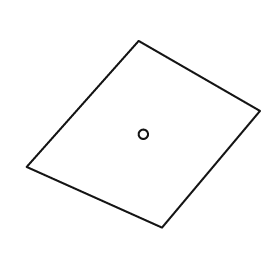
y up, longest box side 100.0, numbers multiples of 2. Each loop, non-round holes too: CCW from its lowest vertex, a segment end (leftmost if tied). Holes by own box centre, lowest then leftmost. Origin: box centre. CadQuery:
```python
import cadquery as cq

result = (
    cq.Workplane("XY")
    .moveTo(8.0, -40.0)
    .lineTo(50.0, 10.0)
    .lineTo(-2.0, 40.0)
    .lineTo(-50.0, -14.0)
    .close()
    .moveTo(0.0, 0.0)
    .circle(2.0)
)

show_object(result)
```